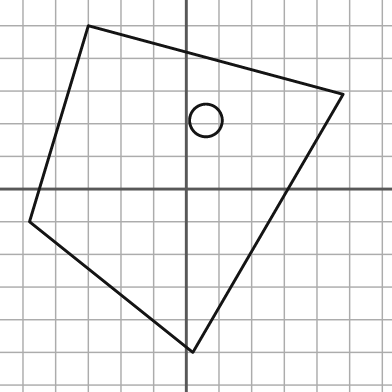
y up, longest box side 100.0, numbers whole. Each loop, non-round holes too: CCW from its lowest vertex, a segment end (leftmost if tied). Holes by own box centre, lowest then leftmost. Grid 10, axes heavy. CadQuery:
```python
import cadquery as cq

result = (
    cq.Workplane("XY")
    .moveTo(2.0, -50.0)
    .lineTo(48.0, 29.0)
    .lineTo(-30.0, 50.0)
    .lineTo(-48.0, -10.0)
    .close()
    .moveTo(6.0, 21.0)
    .circle(5.0)
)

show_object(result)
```